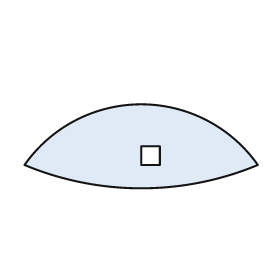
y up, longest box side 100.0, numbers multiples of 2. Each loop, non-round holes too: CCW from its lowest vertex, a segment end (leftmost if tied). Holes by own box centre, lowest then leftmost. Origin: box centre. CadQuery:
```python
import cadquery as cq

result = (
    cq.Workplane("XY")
    .moveTo(-50.0, -8.0)
    .threePointArc((0.0, -18.0), (50.0, -8.0))
    .threePointArc((0.0, 18.0), (-50.0, -8.0))
    .close()
    .moveTo(0.0, -8.0)
    .lineTo(8.0, -8.0)
    .lineTo(8.0, 0.0)
    .lineTo(0.0, 0.0)
    .close()
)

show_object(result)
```